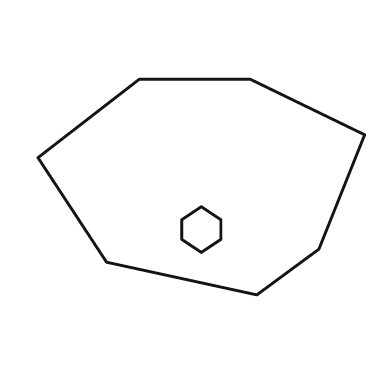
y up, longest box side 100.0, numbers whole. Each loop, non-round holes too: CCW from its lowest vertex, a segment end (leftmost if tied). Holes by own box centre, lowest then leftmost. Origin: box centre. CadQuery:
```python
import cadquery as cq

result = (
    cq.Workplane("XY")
    .moveTo(17.0, -33.0)
    .lineTo(36.0, -19.0)
    .lineTo(50.0, 16.0)
    .lineTo(15.0, 33.0)
    .lineTo(-19.0, 33.0)
    .lineTo(-50.0, 9.0)
    .lineTo(-29.0, -23.0)
    .close()
    .moveTo(0.0, -20.0)
    .lineTo(6.0, -16.0)
    .lineTo(6.0, -10.0)
    .lineTo(0.0, -6.0)
    .lineTo(-6.0, -10.0)
    .lineTo(-6.0, -16.0)
    .close()
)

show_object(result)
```